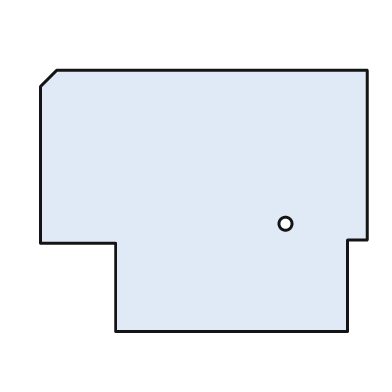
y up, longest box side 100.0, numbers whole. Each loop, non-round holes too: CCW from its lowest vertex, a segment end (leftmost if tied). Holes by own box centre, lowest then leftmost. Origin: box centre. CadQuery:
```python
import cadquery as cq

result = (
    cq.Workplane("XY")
    .moveTo(-27.0, -40.0)
    .lineTo(44.0, -40.0)
    .lineTo(44.0, -12.0)
    .lineTo(50.0, -12.0)
    .lineTo(50.0, 40.0)
    .lineTo(-45.0, 40.0)
    .lineTo(-50.0, 35.0)
    .lineTo(-50.0, -13.0)
    .lineTo(-27.0, -13.0)
    .close()
    .moveTo(25.0, -7.0)
    .circle(2.0)
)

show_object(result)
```